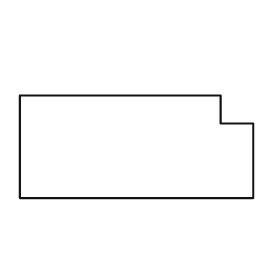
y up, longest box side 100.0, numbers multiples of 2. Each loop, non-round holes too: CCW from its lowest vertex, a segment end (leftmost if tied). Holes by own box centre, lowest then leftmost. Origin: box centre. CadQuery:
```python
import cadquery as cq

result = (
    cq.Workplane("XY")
    .moveTo(-50.0, -22.0)
    .lineTo(50.0, -22.0)
    .lineTo(50.0, 10.0)
    .lineTo(36.0, 10.0)
    .lineTo(36.0, 22.0)
    .lineTo(-50.0, 22.0)
    .close()
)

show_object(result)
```